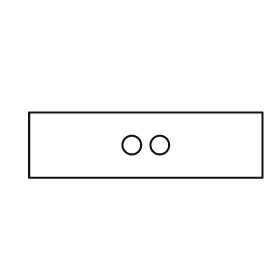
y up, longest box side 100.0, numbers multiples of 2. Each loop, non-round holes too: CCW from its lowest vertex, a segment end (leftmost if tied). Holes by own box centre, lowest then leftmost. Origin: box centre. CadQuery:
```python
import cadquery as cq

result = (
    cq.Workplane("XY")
    .moveTo(-50.0, -14.0)
    .lineTo(50.0, -14.0)
    .lineTo(50.0, 14.0)
    .lineTo(-50.0, 14.0)
    .close()
    .moveTo(-6.0, 0.0)
    .circle(4.0)
    .moveTo(6.0, 0.0)
    .circle(4.0)
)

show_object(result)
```